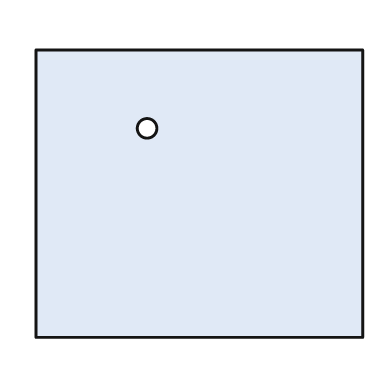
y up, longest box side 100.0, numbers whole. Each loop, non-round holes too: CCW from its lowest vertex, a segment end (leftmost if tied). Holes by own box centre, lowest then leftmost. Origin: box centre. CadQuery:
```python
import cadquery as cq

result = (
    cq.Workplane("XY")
    .moveTo(-50.0, -44.0)
    .lineTo(50.0, -44.0)
    .lineTo(50.0, 44.0)
    .lineTo(-50.0, 44.0)
    .close()
    .moveTo(-16.0, 20.0)
    .circle(3.0)
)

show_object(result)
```